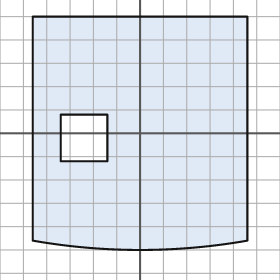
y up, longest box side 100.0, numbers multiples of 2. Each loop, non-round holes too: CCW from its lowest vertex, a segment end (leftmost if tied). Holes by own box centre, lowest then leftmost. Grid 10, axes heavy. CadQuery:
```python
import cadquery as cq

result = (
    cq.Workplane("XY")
    .moveTo(-46.0, -46.0)
    .threePointArc((0.0, -50.0), (46.0, -46.0))
    .lineTo(46.0, 50.0)
    .lineTo(-46.0, 50.0)
    .close()
    .moveTo(-34.0, -12.0)
    .lineTo(-14.0, -12.0)
    .lineTo(-14.0, 8.0)
    .lineTo(-34.0, 8.0)
    .close()
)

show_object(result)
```